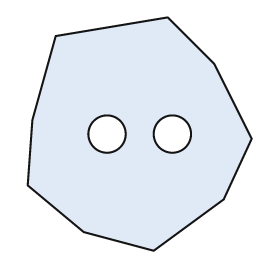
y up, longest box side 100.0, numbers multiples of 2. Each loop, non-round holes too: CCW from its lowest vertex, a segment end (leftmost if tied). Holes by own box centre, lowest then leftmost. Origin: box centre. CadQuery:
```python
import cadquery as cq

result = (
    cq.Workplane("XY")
    .moveTo(6.0, -50.0)
    .lineTo(36.0, -28.0)
    .lineTo(48.0, -2.0)
    .lineTo(32.0, 30.0)
    .lineTo(12.0, 50.0)
    .lineTo(-36.0, 42.0)
    .lineTo(-46.0, 6.0)
    .lineTo(-48.0, -22.0)
    .lineTo(-24.0, -42.0)
    .close()
    .moveTo(-14.0, 0.0)
    .circle(8.0)
    .moveTo(14.0, 0.0)
    .circle(8.0)
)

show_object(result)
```